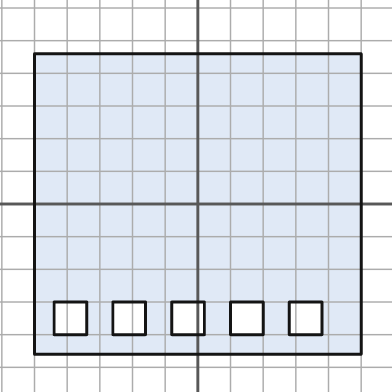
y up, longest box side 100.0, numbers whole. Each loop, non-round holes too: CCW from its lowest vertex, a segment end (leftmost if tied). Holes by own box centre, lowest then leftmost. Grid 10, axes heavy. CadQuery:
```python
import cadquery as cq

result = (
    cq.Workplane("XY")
    .moveTo(-50.0, -46.0)
    .lineTo(50.0, -46.0)
    .lineTo(50.0, 46.0)
    .lineTo(-50.0, 46.0)
    .close()
    .moveTo(-44.0, -40.0)
    .lineTo(-34.0, -40.0)
    .lineTo(-34.0, -30.0)
    .lineTo(-44.0, -30.0)
    .close()
    .moveTo(-26.0, -40.0)
    .lineTo(-16.0, -40.0)
    .lineTo(-16.0, -30.0)
    .lineTo(-26.0, -30.0)
    .close()
    .moveTo(-8.0, -40.0)
    .lineTo(2.0, -40.0)
    .lineTo(2.0, -30.0)
    .lineTo(-8.0, -30.0)
    .close()
    .moveTo(10.0, -40.0)
    .lineTo(20.0, -40.0)
    .lineTo(20.0, -30.0)
    .lineTo(10.0, -30.0)
    .close()
    .moveTo(28.0, -40.0)
    .lineTo(38.0, -40.0)
    .lineTo(38.0, -30.0)
    .lineTo(28.0, -30.0)
    .close()
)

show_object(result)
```